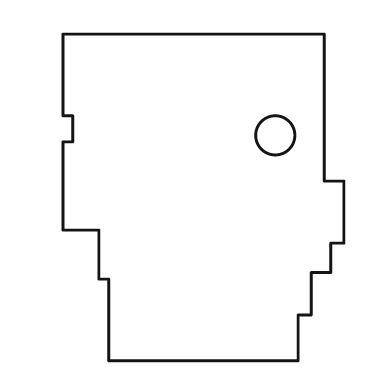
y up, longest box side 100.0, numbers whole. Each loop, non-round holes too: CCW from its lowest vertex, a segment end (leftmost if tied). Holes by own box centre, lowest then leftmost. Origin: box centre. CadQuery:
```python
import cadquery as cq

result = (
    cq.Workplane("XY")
    .moveTo(-29.0, -50.0)
    .lineTo(29.0, -50.0)
    .lineTo(29.0, -36.0)
    .lineTo(33.0, -36.0)
    .lineTo(33.0, -23.0)
    .lineTo(39.0, -23.0)
    .lineTo(39.0, -14.0)
    .lineTo(43.0, -14.0)
    .lineTo(43.0, 5.0)
    .lineTo(37.0, 5.0)
    .lineTo(37.0, 50.0)
    .lineTo(-43.0, 50.0)
    .lineTo(-43.0, 25.0)
    .lineTo(-40.0, 25.0)
    .lineTo(-40.0, 17.0)
    .lineTo(-43.0, 17.0)
    .lineTo(-43.0, -10.0)
    .lineTo(-32.0, -10.0)
    .lineTo(-32.0, -25.0)
    .lineTo(-29.0, -25.0)
    .close()
    .moveTo(22.0, 19.0)
    .circle(6.0)
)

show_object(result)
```